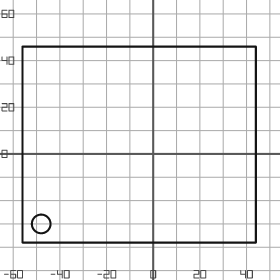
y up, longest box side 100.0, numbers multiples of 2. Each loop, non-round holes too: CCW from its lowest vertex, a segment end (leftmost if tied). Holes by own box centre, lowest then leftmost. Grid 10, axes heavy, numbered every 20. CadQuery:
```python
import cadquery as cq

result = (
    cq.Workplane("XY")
    .moveTo(-56.0, -38.0)
    .lineTo(44.0, -38.0)
    .lineTo(44.0, 46.0)
    .lineTo(-56.0, 46.0)
    .close()
    .moveTo(-48.0, -30.0)
    .circle(4.0)
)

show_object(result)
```